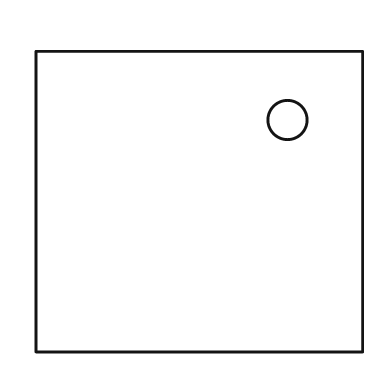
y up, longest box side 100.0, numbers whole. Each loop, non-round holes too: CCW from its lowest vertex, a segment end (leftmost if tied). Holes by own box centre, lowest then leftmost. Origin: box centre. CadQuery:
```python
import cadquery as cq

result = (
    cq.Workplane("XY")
    .moveTo(-50.0, -46.0)
    .lineTo(50.0, -46.0)
    .lineTo(50.0, 46.0)
    .lineTo(-50.0, 46.0)
    .close()
    .moveTo(27.0, 25.0)
    .circle(6.0)
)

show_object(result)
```